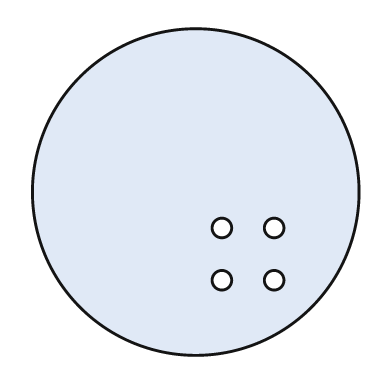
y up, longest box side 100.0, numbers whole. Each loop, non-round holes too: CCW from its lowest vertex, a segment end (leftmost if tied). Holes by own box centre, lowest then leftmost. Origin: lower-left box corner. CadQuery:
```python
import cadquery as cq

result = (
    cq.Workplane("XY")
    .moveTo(50.0, 50.0)
    .circle(50.0)
    .moveTo(58.0, 23.0)
    .circle(3.0)
    .moveTo(74.0, 23.0)
    .circle(3.0)
    .moveTo(58.0, 39.0)
    .circle(3.0)
    .moveTo(74.0, 39.0)
    .circle(3.0)
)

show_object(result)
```